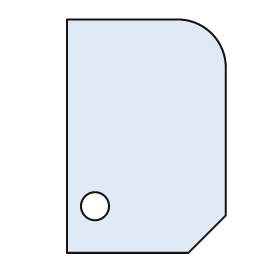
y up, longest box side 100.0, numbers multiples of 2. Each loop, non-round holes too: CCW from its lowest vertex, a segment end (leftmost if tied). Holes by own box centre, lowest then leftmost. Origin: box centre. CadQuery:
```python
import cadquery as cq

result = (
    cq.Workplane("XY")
    .moveTo(-34.0, -50.0)
    .lineTo(18.0, -50.0)
    .lineTo(34.0, -34.0)
    .lineTo(34.0, 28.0)
    .threePointArc((28.0, 44.0), (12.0, 50.0))
    .lineTo(-34.0, 50.0)
    .close()
    .moveTo(-22.0, -30.0)
    .circle(6.0)
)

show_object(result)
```